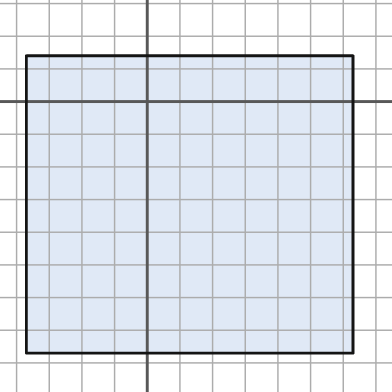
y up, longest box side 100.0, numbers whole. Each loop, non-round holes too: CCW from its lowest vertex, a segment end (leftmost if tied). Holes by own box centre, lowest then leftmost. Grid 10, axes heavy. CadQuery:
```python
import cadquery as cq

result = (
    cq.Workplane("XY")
    .moveTo(-37.0, -77.0)
    .lineTo(63.0, -77.0)
    .lineTo(63.0, 14.0)
    .lineTo(-37.0, 14.0)
    .close()
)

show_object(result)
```